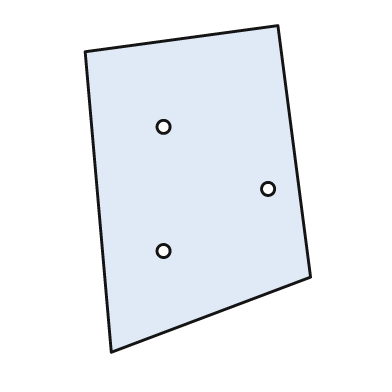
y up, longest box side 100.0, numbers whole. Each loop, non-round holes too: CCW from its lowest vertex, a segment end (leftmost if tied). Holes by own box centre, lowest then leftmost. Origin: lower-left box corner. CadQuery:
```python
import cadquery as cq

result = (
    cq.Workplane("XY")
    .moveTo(8.0, 0.0)
    .lineTo(69.0, 23.0)
    .lineTo(59.0, 100.0)
    .lineTo(0.0, 92.0)
    .close()
    .moveTo(24.0, 31.0)
    .circle(2.0)
    .moveTo(56.0, 50.0)
    .circle(2.0)
    .moveTo(24.0, 69.0)
    .circle(2.0)
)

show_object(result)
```